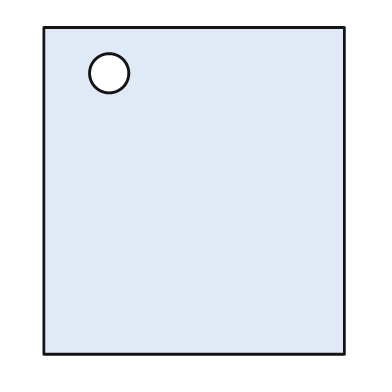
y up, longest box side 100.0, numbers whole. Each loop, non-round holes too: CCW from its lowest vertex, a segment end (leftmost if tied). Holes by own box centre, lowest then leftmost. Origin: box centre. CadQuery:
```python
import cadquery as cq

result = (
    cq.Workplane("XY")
    .moveTo(-46.0, -50.0)
    .lineTo(46.0, -50.0)
    .lineTo(46.0, 50.0)
    .lineTo(-46.0, 50.0)
    .close()
    .moveTo(-26.0, 36.0)
    .circle(6.0)
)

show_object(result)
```